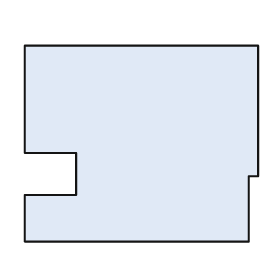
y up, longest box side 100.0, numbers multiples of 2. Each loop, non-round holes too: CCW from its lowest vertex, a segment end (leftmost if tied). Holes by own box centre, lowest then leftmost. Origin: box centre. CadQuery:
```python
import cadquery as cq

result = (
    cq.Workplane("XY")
    .moveTo(-50.0, -42.0)
    .lineTo(46.0, -42.0)
    .lineTo(46.0, -14.0)
    .lineTo(50.0, -14.0)
    .lineTo(50.0, 42.0)
    .lineTo(-50.0, 42.0)
    .lineTo(-50.0, -4.0)
    .lineTo(-28.0, -4.0)
    .lineTo(-28.0, -22.0)
    .lineTo(-50.0, -22.0)
    .close()
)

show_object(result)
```